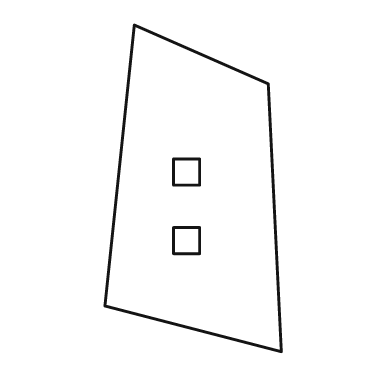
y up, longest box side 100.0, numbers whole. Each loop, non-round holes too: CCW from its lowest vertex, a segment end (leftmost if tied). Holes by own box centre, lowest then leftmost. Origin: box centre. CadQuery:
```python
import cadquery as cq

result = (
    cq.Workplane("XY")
    .moveTo(27.0, -50.0)
    .lineTo(23.0, 32.0)
    .lineTo(-18.0, 50.0)
    .lineTo(-27.0, -36.0)
    .close()
    .moveTo(-6.0, -20.0)
    .lineTo(2.0, -20.0)
    .lineTo(2.0, -12.0)
    .lineTo(-6.0, -12.0)
    .close()
    .moveTo(-6.0, 1.0)
    .lineTo(2.0, 1.0)
    .lineTo(2.0, 9.0)
    .lineTo(-6.0, 9.0)
    .close()
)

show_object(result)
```